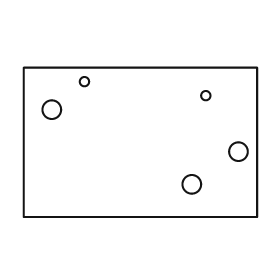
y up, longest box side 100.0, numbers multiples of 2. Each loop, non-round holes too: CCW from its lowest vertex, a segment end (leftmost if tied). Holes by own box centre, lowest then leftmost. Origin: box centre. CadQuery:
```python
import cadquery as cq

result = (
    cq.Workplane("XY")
    .moveTo(-50.0, -32.0)
    .lineTo(50.0, -32.0)
    .lineTo(50.0, 32.0)
    .lineTo(-50.0, 32.0)
    .close()
    .moveTo(22.0, -18.0)
    .circle(4.0)
    .moveTo(42.0, -4.0)
    .circle(4.0)
    .moveTo(-38.0, 14.0)
    .circle(4.0)
    .moveTo(28.0, 20.0)
    .circle(2.0)
    .moveTo(-24.0, 26.0)
    .circle(2.0)
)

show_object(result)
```